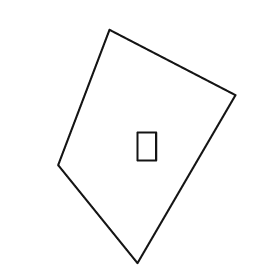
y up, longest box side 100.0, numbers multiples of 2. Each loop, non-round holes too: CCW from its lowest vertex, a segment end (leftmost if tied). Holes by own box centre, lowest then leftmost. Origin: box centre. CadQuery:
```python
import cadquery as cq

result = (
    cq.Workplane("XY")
    .moveTo(-4.0, -50.0)
    .lineTo(38.0, 22.0)
    .lineTo(-16.0, 50.0)
    .lineTo(-38.0, -8.0)
    .close()
    .moveTo(-4.0, -6.0)
    .lineTo(4.0, -6.0)
    .lineTo(4.0, 6.0)
    .lineTo(-4.0, 6.0)
    .close()
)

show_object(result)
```